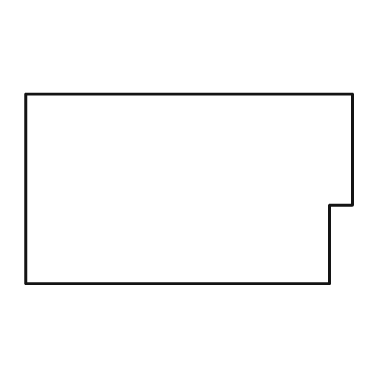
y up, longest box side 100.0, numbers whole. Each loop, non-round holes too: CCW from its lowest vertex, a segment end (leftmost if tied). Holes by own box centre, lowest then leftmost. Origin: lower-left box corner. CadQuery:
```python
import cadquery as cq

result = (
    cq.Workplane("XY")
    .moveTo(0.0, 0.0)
    .lineTo(93.0, 0.0)
    .lineTo(93.0, 24.0)
    .lineTo(100.0, 24.0)
    .lineTo(100.0, 58.0)
    .lineTo(0.0, 58.0)
    .close()
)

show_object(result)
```